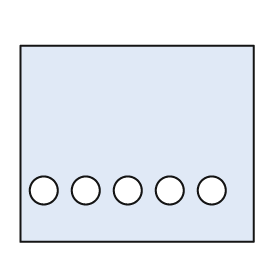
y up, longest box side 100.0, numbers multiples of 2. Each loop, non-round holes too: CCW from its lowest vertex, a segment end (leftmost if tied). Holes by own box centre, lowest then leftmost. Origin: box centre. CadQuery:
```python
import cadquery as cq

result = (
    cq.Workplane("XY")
    .moveTo(-50.0, -42.0)
    .lineTo(50.0, -42.0)
    .lineTo(50.0, 42.0)
    .lineTo(-50.0, 42.0)
    .close()
    .moveTo(-40.0, -20.0)
    .circle(6.0)
    .moveTo(-22.0, -20.0)
    .circle(6.0)
    .moveTo(-4.0, -20.0)
    .circle(6.0)
    .moveTo(14.0, -20.0)
    .circle(6.0)
    .moveTo(32.0, -20.0)
    .circle(6.0)
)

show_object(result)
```